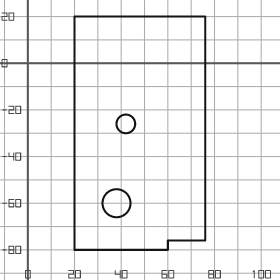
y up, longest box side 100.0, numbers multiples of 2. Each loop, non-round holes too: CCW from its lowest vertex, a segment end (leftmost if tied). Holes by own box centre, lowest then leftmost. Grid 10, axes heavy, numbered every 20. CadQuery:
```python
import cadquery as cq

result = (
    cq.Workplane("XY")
    .moveTo(20.0, -80.0)
    .lineTo(60.0, -80.0)
    .lineTo(60.0, -76.0)
    .lineTo(76.0, -76.0)
    .lineTo(76.0, 20.0)
    .lineTo(20.0, 20.0)
    .close()
    .moveTo(38.0, -60.0)
    .circle(6.0)
    .moveTo(42.0, -26.0)
    .circle(4.0)
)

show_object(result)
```